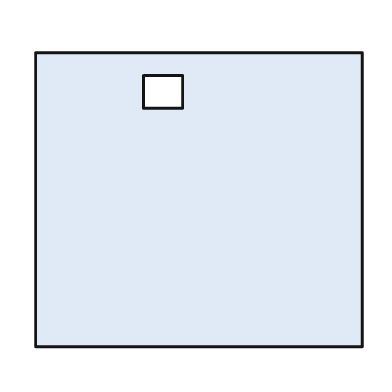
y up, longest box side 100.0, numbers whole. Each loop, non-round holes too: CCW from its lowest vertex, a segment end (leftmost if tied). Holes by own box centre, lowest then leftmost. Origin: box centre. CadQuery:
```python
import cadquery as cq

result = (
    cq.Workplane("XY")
    .moveTo(-50.0, -45.0)
    .lineTo(50.0, -45.0)
    .lineTo(50.0, 45.0)
    .lineTo(-50.0, 45.0)
    .close()
    .moveTo(-17.0, 28.0)
    .lineTo(-5.0, 28.0)
    .lineTo(-5.0, 38.0)
    .lineTo(-17.0, 38.0)
    .close()
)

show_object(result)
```